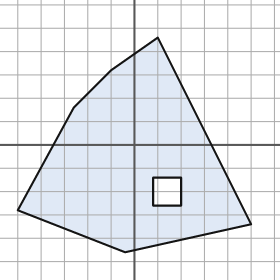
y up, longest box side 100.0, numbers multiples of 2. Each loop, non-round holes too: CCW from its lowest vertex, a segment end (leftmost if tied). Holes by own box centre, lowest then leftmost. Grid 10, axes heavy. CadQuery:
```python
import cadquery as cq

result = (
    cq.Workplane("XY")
    .moveTo(-4.0, -46.0)
    .lineTo(50.0, -34.0)
    .lineTo(10.0, 46.0)
    .lineTo(-10.0, 32.0)
    .lineTo(-26.0, 16.0)
    .lineTo(-50.0, -28.0)
    .close()
    .moveTo(8.0, -26.0)
    .lineTo(20.0, -26.0)
    .lineTo(20.0, -14.0)
    .lineTo(8.0, -14.0)
    .close()
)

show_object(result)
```